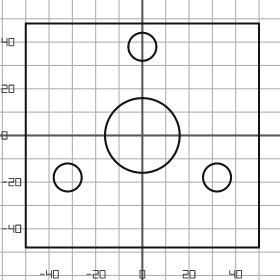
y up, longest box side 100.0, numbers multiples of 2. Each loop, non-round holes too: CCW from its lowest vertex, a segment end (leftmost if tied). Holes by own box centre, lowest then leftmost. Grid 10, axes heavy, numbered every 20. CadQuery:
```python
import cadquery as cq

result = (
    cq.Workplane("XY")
    .moveTo(-50.0, -48.0)
    .lineTo(50.0, -48.0)
    .lineTo(50.0, 48.0)
    .lineTo(-50.0, 48.0)
    .close()
    .moveTo(-32.0, -18.0)
    .circle(6.0)
    .moveTo(32.0, -18.0)
    .circle(6.0)
    .moveTo(0.0, 0.0)
    .circle(16.0)
    .moveTo(0.0, 38.0)
    .circle(6.0)
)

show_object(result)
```